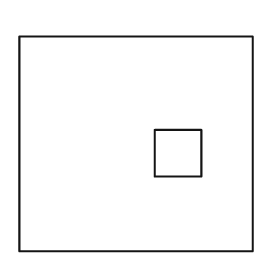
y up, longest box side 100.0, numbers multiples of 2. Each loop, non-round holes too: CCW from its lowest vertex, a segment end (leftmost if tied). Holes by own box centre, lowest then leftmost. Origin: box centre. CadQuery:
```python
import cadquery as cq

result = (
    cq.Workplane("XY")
    .moveTo(-50.0, -46.0)
    .lineTo(50.0, -46.0)
    .lineTo(50.0, 46.0)
    .lineTo(-50.0, 46.0)
    .close()
    .moveTo(8.0, -14.0)
    .lineTo(28.0, -14.0)
    .lineTo(28.0, 6.0)
    .lineTo(8.0, 6.0)
    .close()
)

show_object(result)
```